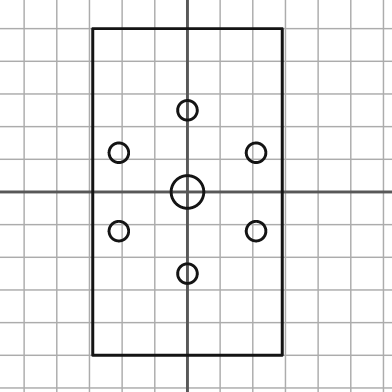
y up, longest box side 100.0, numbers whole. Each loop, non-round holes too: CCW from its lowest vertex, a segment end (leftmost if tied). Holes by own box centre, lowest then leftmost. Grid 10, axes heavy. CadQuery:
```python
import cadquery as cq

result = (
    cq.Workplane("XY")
    .moveTo(-29.0, -50.0)
    .lineTo(29.0, -50.0)
    .lineTo(29.0, 50.0)
    .lineTo(-29.0, 50.0)
    .close()
    .moveTo(0.0, -25.0)
    .circle(3.0)
    .moveTo(-21.0, -12.0)
    .circle(3.0)
    .moveTo(21.0, -12.0)
    .circle(3.0)
    .moveTo(0.0, 0.0)
    .circle(5.0)
    .moveTo(-21.0, 12.0)
    .circle(3.0)
    .moveTo(21.0, 12.0)
    .circle(3.0)
    .moveTo(0.0, 25.0)
    .circle(3.0)
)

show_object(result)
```